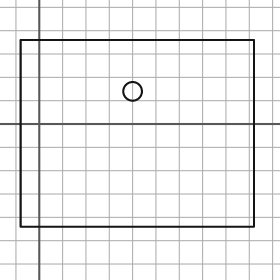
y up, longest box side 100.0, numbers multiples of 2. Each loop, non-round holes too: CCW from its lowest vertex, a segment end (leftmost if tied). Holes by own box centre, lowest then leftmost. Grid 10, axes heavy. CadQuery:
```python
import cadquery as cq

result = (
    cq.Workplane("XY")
    .moveTo(-8.0, -44.0)
    .lineTo(92.0, -44.0)
    .lineTo(92.0, 36.0)
    .lineTo(-8.0, 36.0)
    .close()
    .moveTo(40.0, 14.0)
    .circle(4.0)
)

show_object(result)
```